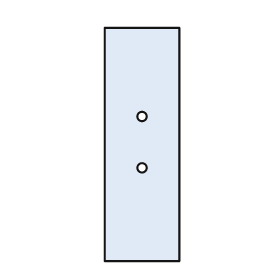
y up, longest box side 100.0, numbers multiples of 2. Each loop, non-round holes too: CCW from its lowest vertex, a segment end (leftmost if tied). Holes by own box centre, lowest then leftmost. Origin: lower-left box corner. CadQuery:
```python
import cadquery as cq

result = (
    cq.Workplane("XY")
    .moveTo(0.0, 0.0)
    .lineTo(32.0, 0.0)
    .lineTo(32.0, 100.0)
    .lineTo(0.0, 100.0)
    .close()
    .moveTo(16.0, 40.0)
    .circle(2.0)
    .moveTo(16.0, 62.0)
    .circle(2.0)
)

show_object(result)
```